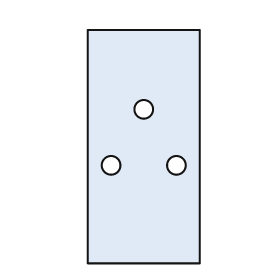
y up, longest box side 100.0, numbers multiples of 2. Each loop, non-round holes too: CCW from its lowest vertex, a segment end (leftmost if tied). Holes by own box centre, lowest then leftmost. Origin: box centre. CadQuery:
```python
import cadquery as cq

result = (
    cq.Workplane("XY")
    .moveTo(-24.0, -50.0)
    .lineTo(24.0, -50.0)
    .lineTo(24.0, 50.0)
    .lineTo(-24.0, 50.0)
    .close()
    .moveTo(-14.0, -8.0)
    .circle(4.0)
    .moveTo(14.0, -8.0)
    .circle(4.0)
    .moveTo(0.0, 16.0)
    .circle(4.0)
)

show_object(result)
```